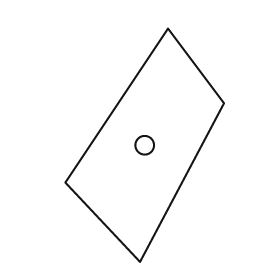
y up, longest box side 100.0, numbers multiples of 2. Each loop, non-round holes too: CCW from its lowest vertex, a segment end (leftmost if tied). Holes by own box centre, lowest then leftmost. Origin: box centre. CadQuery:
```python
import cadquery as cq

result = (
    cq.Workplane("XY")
    .moveTo(-2.0, -50.0)
    .lineTo(34.0, 18.0)
    .lineTo(10.0, 50.0)
    .lineTo(-34.0, -16.0)
    .close()
    .moveTo(0.0, 0.0)
    .circle(4.0)
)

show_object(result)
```